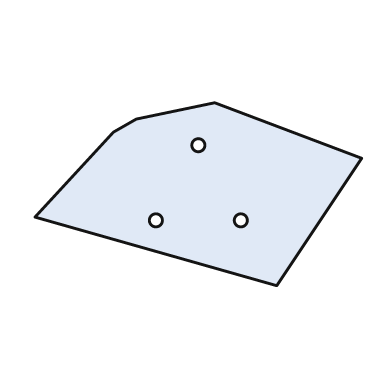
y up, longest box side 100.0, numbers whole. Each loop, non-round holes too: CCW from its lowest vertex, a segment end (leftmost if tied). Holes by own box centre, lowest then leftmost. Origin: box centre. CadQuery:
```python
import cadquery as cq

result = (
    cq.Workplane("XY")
    .moveTo(24.0, -28.0)
    .lineTo(50.0, 11.0)
    .lineTo(5.0, 28.0)
    .lineTo(-19.0, 23.0)
    .lineTo(-26.0, 19.0)
    .lineTo(-50.0, -7.0)
    .close()
    .moveTo(-13.0, -8.0)
    .circle(2.0)
    .moveTo(13.0, -8.0)
    .circle(2.0)
    .moveTo(0.0, 15.0)
    .circle(2.0)
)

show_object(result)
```